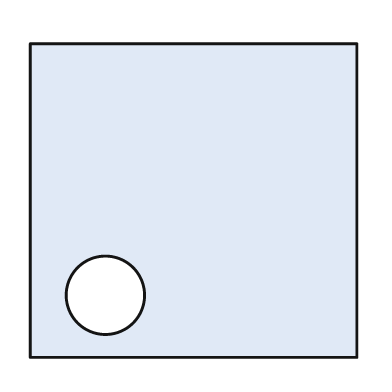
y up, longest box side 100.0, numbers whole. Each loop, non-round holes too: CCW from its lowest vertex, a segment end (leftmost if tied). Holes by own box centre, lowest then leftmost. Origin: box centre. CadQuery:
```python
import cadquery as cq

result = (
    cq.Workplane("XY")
    .moveTo(-50.0, -48.0)
    .lineTo(50.0, -48.0)
    .lineTo(50.0, 48.0)
    .lineTo(-50.0, 48.0)
    .close()
    .moveTo(-27.0, -29.0)
    .circle(12.0)
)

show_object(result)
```